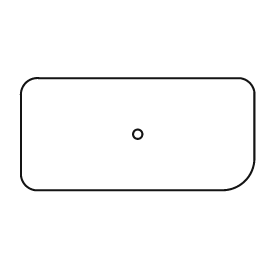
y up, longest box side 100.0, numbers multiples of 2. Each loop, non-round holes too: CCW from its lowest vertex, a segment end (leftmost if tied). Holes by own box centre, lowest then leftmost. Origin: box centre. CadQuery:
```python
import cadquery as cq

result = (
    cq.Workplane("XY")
    .moveTo(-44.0, -24.0)
    .lineTo(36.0, -24.0)
    .threePointArc((46.0, -20.0), (50.0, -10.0))
    .lineTo(50.0, 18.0)
    .threePointArc((48.0, 22.0), (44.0, 24.0))
    .lineTo(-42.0, 24.0)
    .threePointArc((-48.0, 22.0), (-50.0, 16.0))
    .lineTo(-50.0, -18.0)
    .threePointArc((-48.0, -22.0), (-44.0, -24.0))
    .close()
    .moveTo(0.0, 0.0)
    .circle(2.0)
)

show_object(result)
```